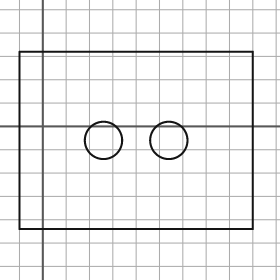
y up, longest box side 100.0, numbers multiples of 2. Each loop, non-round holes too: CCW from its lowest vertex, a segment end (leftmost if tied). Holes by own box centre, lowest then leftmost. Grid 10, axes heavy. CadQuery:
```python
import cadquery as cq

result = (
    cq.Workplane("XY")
    .moveTo(-10.0, -44.0)
    .lineTo(90.0, -44.0)
    .lineTo(90.0, 32.0)
    .lineTo(-10.0, 32.0)
    .close()
    .moveTo(26.0, -6.0)
    .circle(8.0)
    .moveTo(54.0, -6.0)
    .circle(8.0)
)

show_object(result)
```